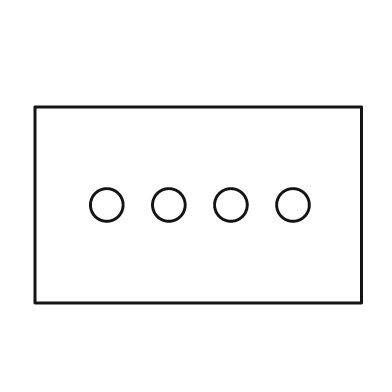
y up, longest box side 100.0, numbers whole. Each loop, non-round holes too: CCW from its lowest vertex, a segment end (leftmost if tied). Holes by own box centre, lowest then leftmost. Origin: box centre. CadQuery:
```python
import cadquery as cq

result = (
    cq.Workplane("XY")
    .moveTo(-50.0, -30.0)
    .lineTo(50.0, -30.0)
    .lineTo(50.0, 30.0)
    .lineTo(-50.0, 30.0)
    .close()
    .moveTo(-28.0, 0.0)
    .circle(5.0)
    .moveTo(-9.0, 0.0)
    .circle(5.0)
    .moveTo(10.0, 0.0)
    .circle(5.0)
    .moveTo(29.0, 0.0)
    .circle(5.0)
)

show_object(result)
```